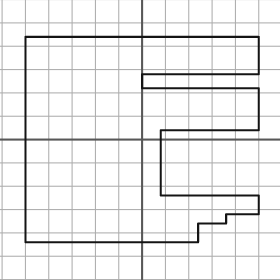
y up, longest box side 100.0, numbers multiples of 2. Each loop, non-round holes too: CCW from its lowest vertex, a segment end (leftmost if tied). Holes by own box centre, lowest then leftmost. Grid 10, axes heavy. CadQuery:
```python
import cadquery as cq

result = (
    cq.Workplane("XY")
    .moveTo(-50.0, -44.0)
    .lineTo(24.0, -44.0)
    .lineTo(24.0, -36.0)
    .lineTo(36.0, -36.0)
    .lineTo(36.0, -32.0)
    .lineTo(50.0, -32.0)
    .lineTo(50.0, -24.0)
    .lineTo(8.0, -24.0)
    .lineTo(8.0, 4.0)
    .lineTo(50.0, 4.0)
    .lineTo(50.0, 22.0)
    .lineTo(0.0, 22.0)
    .lineTo(0.0, 28.0)
    .lineTo(50.0, 28.0)
    .lineTo(50.0, 44.0)
    .lineTo(-50.0, 44.0)
    .close()
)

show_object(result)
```